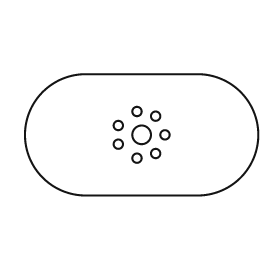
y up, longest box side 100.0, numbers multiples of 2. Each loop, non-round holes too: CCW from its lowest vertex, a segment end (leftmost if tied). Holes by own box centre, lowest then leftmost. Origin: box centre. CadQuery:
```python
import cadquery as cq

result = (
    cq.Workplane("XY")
    .moveTo(-24.0, -26.0)
    .lineTo(24.0, -26.0)
    .threePointArc((50.0, 0.0), (24.0, 26.0))
    .lineTo(-24.0, 26.0)
    .threePointArc((-50.0, 0.0), (-24.0, -26.0))
    .close()
    .moveTo(-2.0, -10.0)
    .circle(2.0)
    .moveTo(6.0, -8.0)
    .circle(2.0)
    .moveTo(-10.0, -4.0)
    .circle(2.0)
    .moveTo(0.0, 0.0)
    .circle(4.0)
    .moveTo(10.0, 0.0)
    .circle(2.0)
    .moveTo(-10.0, 4.0)
    .circle(2.0)
    .moveTo(6.0, 8.0)
    .circle(2.0)
    .moveTo(-2.0, 10.0)
    .circle(2.0)
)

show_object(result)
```